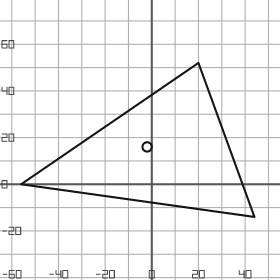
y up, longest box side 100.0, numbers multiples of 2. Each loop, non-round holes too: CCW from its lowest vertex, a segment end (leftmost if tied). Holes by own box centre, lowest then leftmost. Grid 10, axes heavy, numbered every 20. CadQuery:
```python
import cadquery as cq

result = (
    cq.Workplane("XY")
    .moveTo(44.0, -14.0)
    .lineTo(20.0, 52.0)
    .lineTo(-56.0, 0.0)
    .close()
    .moveTo(-2.0, 16.0)
    .circle(2.0)
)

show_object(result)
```